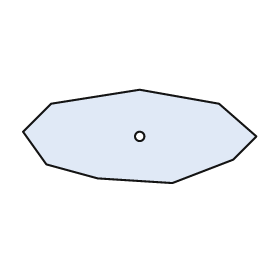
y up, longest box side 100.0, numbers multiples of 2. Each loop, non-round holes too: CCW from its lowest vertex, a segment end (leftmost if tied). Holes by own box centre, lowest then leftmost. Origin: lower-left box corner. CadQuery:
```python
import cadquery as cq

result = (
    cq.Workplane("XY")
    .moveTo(64.0, 0.0)
    .lineTo(90.0, 10.0)
    .lineTo(100.0, 20.0)
    .lineTo(84.0, 34.0)
    .lineTo(50.0, 40.0)
    .lineTo(12.0, 34.0)
    .lineTo(0.0, 22.0)
    .lineTo(10.0, 8.0)
    .lineTo(32.0, 2.0)
    .close()
    .moveTo(50.0, 20.0)
    .circle(2.0)
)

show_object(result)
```